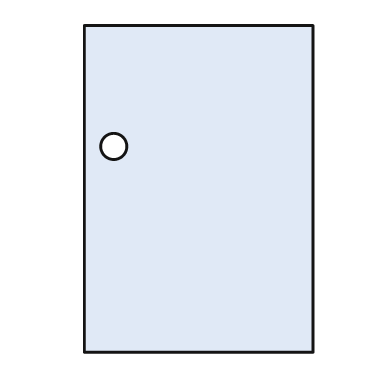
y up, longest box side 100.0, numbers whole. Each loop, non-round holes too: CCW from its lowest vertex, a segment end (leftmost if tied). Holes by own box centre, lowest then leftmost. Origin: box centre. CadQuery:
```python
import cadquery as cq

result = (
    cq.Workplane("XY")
    .moveTo(-35.0, -50.0)
    .lineTo(35.0, -50.0)
    .lineTo(35.0, 50.0)
    .lineTo(-35.0, 50.0)
    .close()
    .moveTo(-26.0, 13.0)
    .circle(4.0)
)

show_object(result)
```